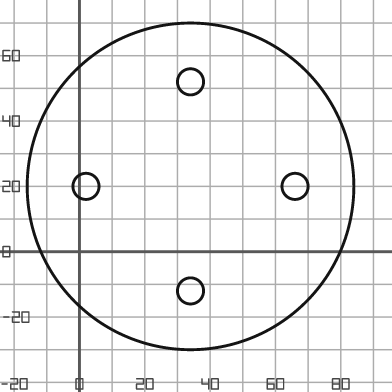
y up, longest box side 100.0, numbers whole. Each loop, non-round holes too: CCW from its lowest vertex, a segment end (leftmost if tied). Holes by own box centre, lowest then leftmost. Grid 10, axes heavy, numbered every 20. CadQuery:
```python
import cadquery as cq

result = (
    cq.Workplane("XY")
    .moveTo(34.0, 20.0)
    .circle(50.0)
    .moveTo(34.0, -12.0)
    .circle(4.0)
    .moveTo(2.0, 20.0)
    .circle(4.0)
    .moveTo(66.0, 20.0)
    .circle(4.0)
    .moveTo(34.0, 52.0)
    .circle(4.0)
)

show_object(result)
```